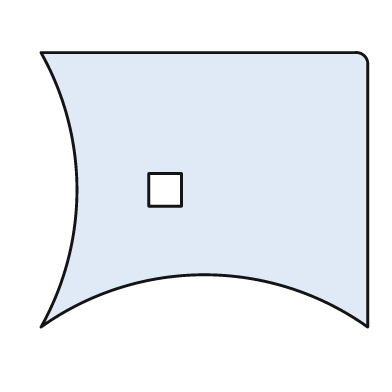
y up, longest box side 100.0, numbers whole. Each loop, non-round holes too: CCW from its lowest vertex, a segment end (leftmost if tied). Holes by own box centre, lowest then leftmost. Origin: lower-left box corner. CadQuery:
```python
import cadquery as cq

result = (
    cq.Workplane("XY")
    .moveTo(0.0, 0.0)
    .threePointArc((50.0, 16.0), (100.0, 0.0))
    .lineTo(100.0, 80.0)
    .threePointArc((99.0, 83.0), (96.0, 84.0))
    .lineTo(0.0, 84.0)
    .threePointArc((11.0, 42.0), (0.0, 0.0))
    .close()
    .moveTo(33.0, 37.0)
    .lineTo(43.0, 37.0)
    .lineTo(43.0, 47.0)
    .lineTo(33.0, 47.0)
    .close()
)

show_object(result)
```